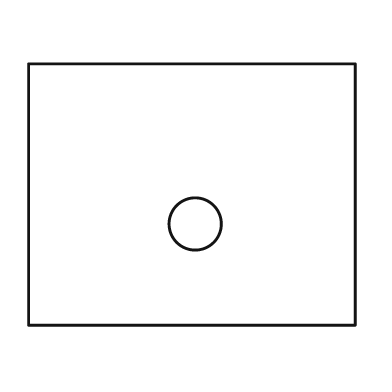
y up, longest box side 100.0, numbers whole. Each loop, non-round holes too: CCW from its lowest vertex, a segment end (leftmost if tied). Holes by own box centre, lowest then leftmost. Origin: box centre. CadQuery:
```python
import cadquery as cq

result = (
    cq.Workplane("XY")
    .moveTo(-50.0, -40.0)
    .lineTo(50.0, -40.0)
    .lineTo(50.0, 40.0)
    .lineTo(-50.0, 40.0)
    .close()
    .moveTo(1.0, -9.0)
    .circle(8.0)
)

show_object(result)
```